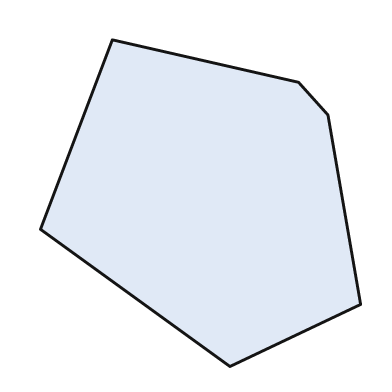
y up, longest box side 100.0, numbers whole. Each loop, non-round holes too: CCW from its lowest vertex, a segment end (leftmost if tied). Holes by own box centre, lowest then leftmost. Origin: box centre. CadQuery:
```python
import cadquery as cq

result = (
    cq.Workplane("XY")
    .moveTo(9.0, -50.0)
    .lineTo(49.0, -31.0)
    .lineTo(39.0, 27.0)
    .lineTo(30.0, 37.0)
    .lineTo(-27.0, 50.0)
    .lineTo(-49.0, -8.0)
    .close()
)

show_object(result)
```